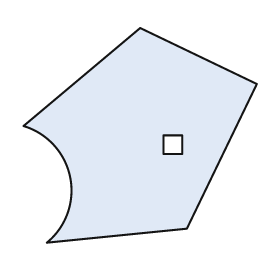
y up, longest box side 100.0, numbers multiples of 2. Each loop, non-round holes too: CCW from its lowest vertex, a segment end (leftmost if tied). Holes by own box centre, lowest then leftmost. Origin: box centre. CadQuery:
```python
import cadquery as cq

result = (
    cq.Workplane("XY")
    .moveTo(-40.0, -46.0)
    .lineTo(20.0, -40.0)
    .lineTo(50.0, 22.0)
    .lineTo(0.0, 46.0)
    .lineTo(-50.0, 4.0)
    .threePointArc((-30.0, -18.0), (-40.0, -46.0))
    .close()
    .moveTo(10.0, -8.0)
    .lineTo(18.0, -8.0)
    .lineTo(18.0, 0.0)
    .lineTo(10.0, 0.0)
    .close()
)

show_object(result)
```